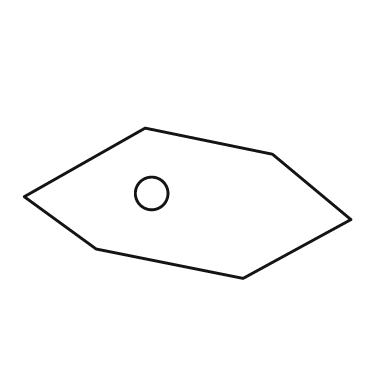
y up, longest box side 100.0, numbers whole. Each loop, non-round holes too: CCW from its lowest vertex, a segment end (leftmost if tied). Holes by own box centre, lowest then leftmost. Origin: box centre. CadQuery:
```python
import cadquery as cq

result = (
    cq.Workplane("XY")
    .moveTo(17.0, -23.0)
    .lineTo(50.0, -5.0)
    .lineTo(26.0, 15.0)
    .lineTo(-13.0, 23.0)
    .lineTo(-50.0, 2.0)
    .lineTo(-28.0, -14.0)
    .close()
    .moveTo(-11.0, 3.0)
    .circle(5.0)
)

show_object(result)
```